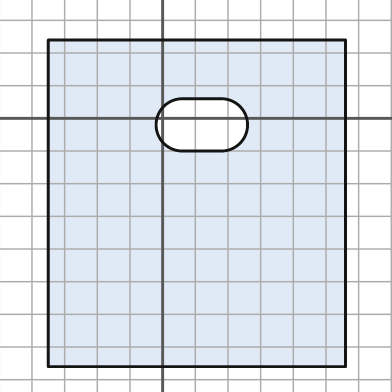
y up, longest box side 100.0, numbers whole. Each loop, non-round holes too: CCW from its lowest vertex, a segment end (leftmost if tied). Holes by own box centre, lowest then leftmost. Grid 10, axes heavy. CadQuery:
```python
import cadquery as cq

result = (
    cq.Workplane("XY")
    .moveTo(-35.0, -76.0)
    .lineTo(56.0, -76.0)
    .lineTo(56.0, 24.0)
    .lineTo(-35.0, 24.0)
    .close()
    .moveTo(6.0, -10.0)
    .lineTo(18.0, -10.0)
    .threePointArc((26.0, -2.0), (18.0, 6.0))
    .lineTo(6.0, 6.0)
    .threePointArc((-2.0, -2.0), (6.0, -10.0))
    .close()
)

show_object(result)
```